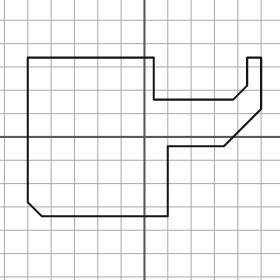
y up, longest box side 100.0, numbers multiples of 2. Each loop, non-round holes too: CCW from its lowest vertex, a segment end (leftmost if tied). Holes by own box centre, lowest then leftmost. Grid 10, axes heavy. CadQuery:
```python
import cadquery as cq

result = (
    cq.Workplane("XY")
    .moveTo(-44.0, -34.0)
    .lineTo(10.0, -34.0)
    .lineTo(10.0, -4.0)
    .lineTo(34.0, -4.0)
    .lineTo(50.0, 12.0)
    .lineTo(50.0, 34.0)
    .lineTo(44.0, 34.0)
    .lineTo(44.0, 22.0)
    .lineTo(38.0, 16.0)
    .lineTo(4.0, 16.0)
    .lineTo(4.0, 34.0)
    .lineTo(-50.0, 34.0)
    .lineTo(-50.0, -28.0)
    .close()
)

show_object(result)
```